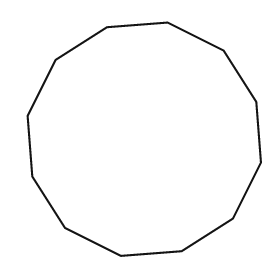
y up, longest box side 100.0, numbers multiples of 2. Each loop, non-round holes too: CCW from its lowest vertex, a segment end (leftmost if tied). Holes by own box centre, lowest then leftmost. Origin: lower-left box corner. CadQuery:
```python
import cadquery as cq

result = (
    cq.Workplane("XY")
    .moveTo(40.0, 0.0)
    .lineTo(66.0, 2.0)
    .lineTo(88.0, 16.0)
    .lineTo(100.0, 40.0)
    .lineTo(98.0, 66.0)
    .lineTo(84.0, 88.0)
    .lineTo(60.0, 100.0)
    .lineTo(34.0, 98.0)
    .lineTo(12.0, 84.0)
    .lineTo(0.0, 60.0)
    .lineTo(2.0, 34.0)
    .lineTo(16.0, 12.0)
    .close()
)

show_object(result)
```